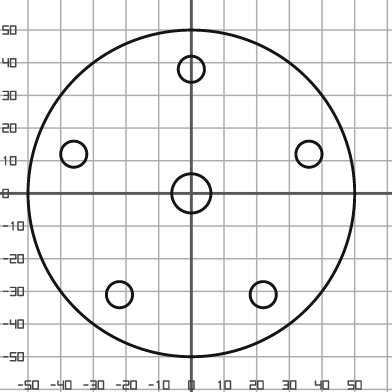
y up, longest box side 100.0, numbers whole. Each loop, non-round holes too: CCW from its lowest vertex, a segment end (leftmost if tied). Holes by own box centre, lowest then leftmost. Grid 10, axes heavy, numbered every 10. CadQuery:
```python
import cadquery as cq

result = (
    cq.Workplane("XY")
    .moveTo(0.0, 0.0)
    .circle(50.0)
    .moveTo(-22.0, -31.0)
    .circle(4.0)
    .moveTo(22.0, -31.0)
    .circle(4.0)
    .moveTo(0.0, 0.0)
    .circle(6.0)
    .moveTo(-36.0, 12.0)
    .circle(4.0)
    .moveTo(36.0, 12.0)
    .circle(4.0)
    .moveTo(0.0, 38.0)
    .circle(4.0)
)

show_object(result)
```